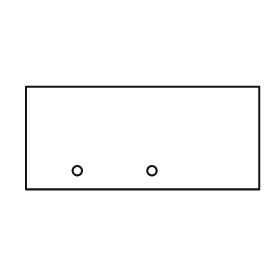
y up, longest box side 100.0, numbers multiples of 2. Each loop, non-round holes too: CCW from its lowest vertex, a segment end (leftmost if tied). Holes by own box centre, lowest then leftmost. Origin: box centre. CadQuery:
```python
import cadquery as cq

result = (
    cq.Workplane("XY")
    .moveTo(-50.0, -22.0)
    .lineTo(50.0, -22.0)
    .lineTo(50.0, 22.0)
    .lineTo(-50.0, 22.0)
    .close()
    .moveTo(-28.0, -14.0)
    .circle(2.0)
    .moveTo(4.0, -14.0)
    .circle(2.0)
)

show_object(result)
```